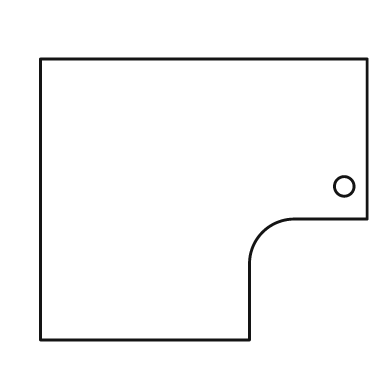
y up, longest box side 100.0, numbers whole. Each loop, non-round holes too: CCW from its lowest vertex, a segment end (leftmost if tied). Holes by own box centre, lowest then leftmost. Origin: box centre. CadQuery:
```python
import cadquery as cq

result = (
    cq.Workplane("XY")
    .moveTo(-50.0, -43.0)
    .lineTo(14.0, -43.0)
    .lineTo(14.0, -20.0)
    .threePointArc((18.0, -10.0), (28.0, -6.0))
    .lineTo(50.0, -6.0)
    .lineTo(50.0, 43.0)
    .lineTo(-50.0, 43.0)
    .close()
    .moveTo(43.0, 4.0)
    .circle(3.0)
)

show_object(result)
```